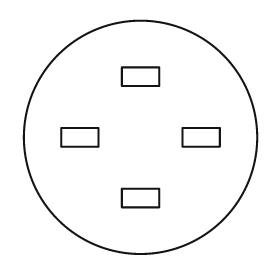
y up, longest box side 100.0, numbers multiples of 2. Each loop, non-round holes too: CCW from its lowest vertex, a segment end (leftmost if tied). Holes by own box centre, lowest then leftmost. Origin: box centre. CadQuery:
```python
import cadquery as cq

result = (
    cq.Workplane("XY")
    .moveTo(0.0, 0.0)
    .circle(50.0)
    .moveTo(-8.0, -30.0)
    .lineTo(8.0, -30.0)
    .lineTo(8.0, -22.0)
    .lineTo(-8.0, -22.0)
    .close()
    .moveTo(-34.0, -4.0)
    .lineTo(-18.0, -4.0)
    .lineTo(-18.0, 4.0)
    .lineTo(-34.0, 4.0)
    .close()
    .moveTo(18.0, -4.0)
    .lineTo(34.0, -4.0)
    .lineTo(34.0, 4.0)
    .lineTo(18.0, 4.0)
    .close()
    .moveTo(-8.0, 22.0)
    .lineTo(8.0, 22.0)
    .lineTo(8.0, 30.0)
    .lineTo(-8.0, 30.0)
    .close()
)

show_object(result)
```